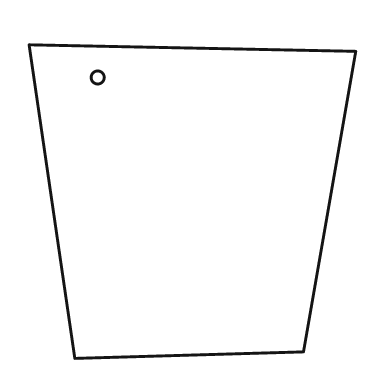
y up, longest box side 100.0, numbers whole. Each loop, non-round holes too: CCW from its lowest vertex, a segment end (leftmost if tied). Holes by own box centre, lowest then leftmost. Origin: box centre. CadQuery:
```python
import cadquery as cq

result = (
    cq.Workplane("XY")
    .moveTo(-36.0, -48.0)
    .lineTo(34.0, -46.0)
    .lineTo(50.0, 46.0)
    .lineTo(-50.0, 48.0)
    .close()
    .moveTo(-29.0, 38.0)
    .circle(2.0)
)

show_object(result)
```